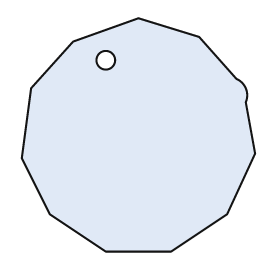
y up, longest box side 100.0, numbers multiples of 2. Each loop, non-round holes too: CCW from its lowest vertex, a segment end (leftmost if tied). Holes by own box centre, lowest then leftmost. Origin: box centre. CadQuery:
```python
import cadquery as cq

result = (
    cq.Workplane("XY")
    .moveTo(-14.0, -50.0)
    .lineTo(14.0, -50.0)
    .lineTo(38.0, -34.0)
    .lineTo(50.0, -8.0)
    .lineTo(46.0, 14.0)
    .threePointArc((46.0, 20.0), (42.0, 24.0))
    .lineTo(26.0, 42.0)
    .lineTo(0.0, 50.0)
    .lineTo(-28.0, 40.0)
    .lineTo(-46.0, 20.0)
    .lineTo(-50.0, -10.0)
    .lineTo(-38.0, -34.0)
    .close()
    .moveTo(-14.0, 32.0)
    .circle(4.0)
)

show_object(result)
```